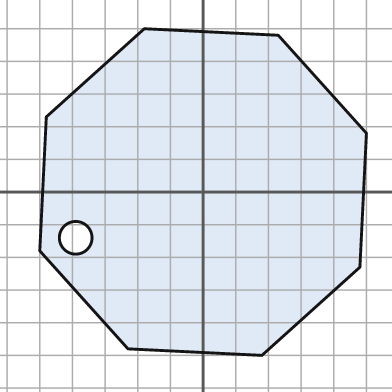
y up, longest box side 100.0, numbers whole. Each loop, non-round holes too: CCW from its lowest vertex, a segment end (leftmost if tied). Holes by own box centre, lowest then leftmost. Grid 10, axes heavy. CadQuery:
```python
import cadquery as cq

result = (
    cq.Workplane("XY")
    .moveTo(18.0, -50.0)
    .lineTo(48.0, -23.0)
    .lineTo(50.0, 18.0)
    .lineTo(23.0, 48.0)
    .lineTo(-18.0, 50.0)
    .lineTo(-48.0, 23.0)
    .lineTo(-50.0, -18.0)
    .lineTo(-23.0, -48.0)
    .close()
    .moveTo(-39.0, -14.0)
    .circle(5.0)
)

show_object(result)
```